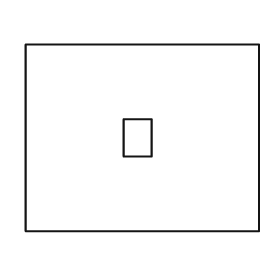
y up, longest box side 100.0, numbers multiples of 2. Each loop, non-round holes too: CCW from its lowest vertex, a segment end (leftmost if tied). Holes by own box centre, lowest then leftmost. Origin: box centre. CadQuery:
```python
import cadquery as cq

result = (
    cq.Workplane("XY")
    .moveTo(-50.0, -40.0)
    .lineTo(50.0, -40.0)
    .lineTo(50.0, 40.0)
    .lineTo(-50.0, 40.0)
    .close()
    .moveTo(-8.0, -8.0)
    .lineTo(4.0, -8.0)
    .lineTo(4.0, 8.0)
    .lineTo(-8.0, 8.0)
    .close()
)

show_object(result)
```